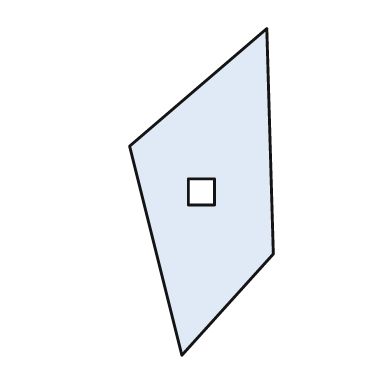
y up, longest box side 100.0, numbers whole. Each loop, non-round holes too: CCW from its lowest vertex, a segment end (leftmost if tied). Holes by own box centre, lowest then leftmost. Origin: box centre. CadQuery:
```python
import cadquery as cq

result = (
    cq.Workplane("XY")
    .moveTo(-6.0, -50.0)
    .lineTo(22.0, -19.0)
    .lineTo(20.0, 50.0)
    .lineTo(-22.0, 14.0)
    .close()
    .moveTo(-4.0, -4.0)
    .lineTo(4.0, -4.0)
    .lineTo(4.0, 4.0)
    .lineTo(-4.0, 4.0)
    .close()
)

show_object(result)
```